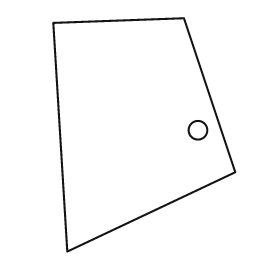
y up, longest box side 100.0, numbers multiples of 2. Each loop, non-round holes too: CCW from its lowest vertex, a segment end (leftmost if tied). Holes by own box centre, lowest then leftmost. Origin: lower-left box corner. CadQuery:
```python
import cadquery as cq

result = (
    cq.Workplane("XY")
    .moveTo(6.0, 0.0)
    .lineTo(78.0, 34.0)
    .lineTo(56.0, 100.0)
    .lineTo(0.0, 98.0)
    .close()
    .moveTo(62.0, 52.0)
    .circle(4.0)
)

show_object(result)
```